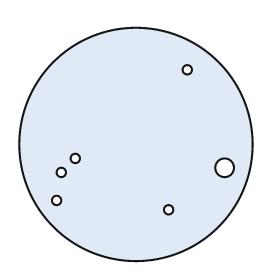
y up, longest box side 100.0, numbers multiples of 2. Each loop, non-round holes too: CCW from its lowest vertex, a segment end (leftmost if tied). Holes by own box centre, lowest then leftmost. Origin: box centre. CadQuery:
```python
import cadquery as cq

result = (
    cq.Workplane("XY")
    .moveTo(0.0, 0.0)
    .circle(50.0)
    .moveTo(14.0, -28.0)
    .circle(2.0)
    .moveTo(-34.0, -24.0)
    .circle(2.0)
    .moveTo(-32.0, -12.0)
    .circle(2.0)
    .moveTo(38.0, -10.0)
    .circle(4.0)
    .moveTo(-26.0, -6.0)
    .circle(2.0)
    .moveTo(22.0, 32.0)
    .circle(2.0)
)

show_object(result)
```